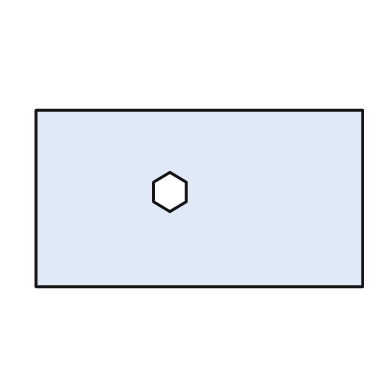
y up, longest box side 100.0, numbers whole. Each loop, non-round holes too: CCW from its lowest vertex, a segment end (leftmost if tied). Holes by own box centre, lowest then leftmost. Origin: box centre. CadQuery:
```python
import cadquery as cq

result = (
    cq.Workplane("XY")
    .moveTo(-50.0, -27.0)
    .lineTo(50.0, -27.0)
    .lineTo(50.0, 27.0)
    .lineTo(-50.0, 27.0)
    .close()
    .moveTo(-9.0, -4.0)
    .lineTo(-4.0, -1.0)
    .lineTo(-4.0, 5.0)
    .lineTo(-9.0, 8.0)
    .lineTo(-14.0, 5.0)
    .lineTo(-14.0, -1.0)
    .close()
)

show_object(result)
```